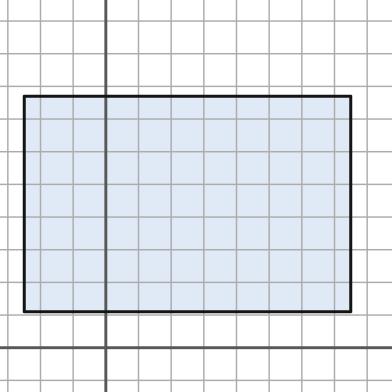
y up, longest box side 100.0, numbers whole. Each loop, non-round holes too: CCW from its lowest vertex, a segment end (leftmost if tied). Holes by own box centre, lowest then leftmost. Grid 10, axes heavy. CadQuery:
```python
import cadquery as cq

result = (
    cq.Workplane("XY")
    .moveTo(-25.0, 11.0)
    .lineTo(75.0, 11.0)
    .lineTo(75.0, 77.0)
    .lineTo(-25.0, 77.0)
    .close()
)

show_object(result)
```